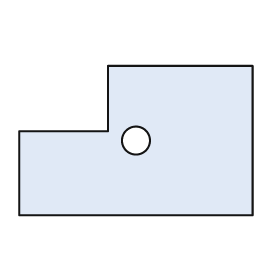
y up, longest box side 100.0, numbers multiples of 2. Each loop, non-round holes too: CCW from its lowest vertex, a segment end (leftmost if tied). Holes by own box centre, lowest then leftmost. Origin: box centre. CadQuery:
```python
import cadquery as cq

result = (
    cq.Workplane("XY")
    .moveTo(-50.0, -32.0)
    .lineTo(50.0, -32.0)
    .lineTo(50.0, 32.0)
    .lineTo(-12.0, 32.0)
    .lineTo(-12.0, 4.0)
    .lineTo(-50.0, 4.0)
    .close()
    .moveTo(0.0, 0.0)
    .circle(6.0)
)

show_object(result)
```